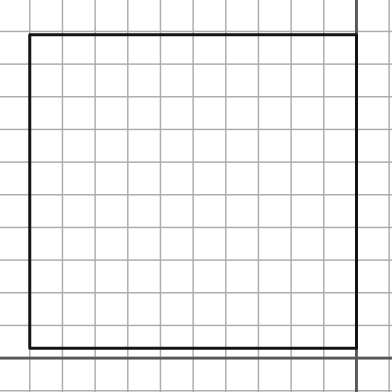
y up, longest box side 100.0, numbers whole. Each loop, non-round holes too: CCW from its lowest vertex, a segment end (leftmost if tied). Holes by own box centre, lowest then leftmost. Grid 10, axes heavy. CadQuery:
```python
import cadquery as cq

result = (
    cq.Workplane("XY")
    .moveTo(-100.0, 3.0)
    .lineTo(0.0, 3.0)
    .lineTo(0.0, 99.0)
    .lineTo(-100.0, 99.0)
    .close()
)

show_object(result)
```